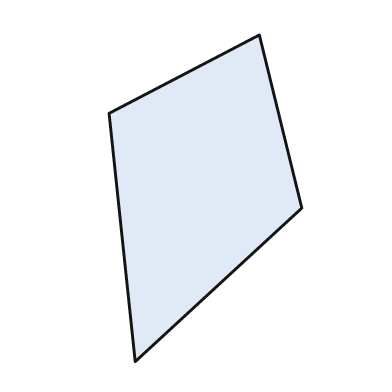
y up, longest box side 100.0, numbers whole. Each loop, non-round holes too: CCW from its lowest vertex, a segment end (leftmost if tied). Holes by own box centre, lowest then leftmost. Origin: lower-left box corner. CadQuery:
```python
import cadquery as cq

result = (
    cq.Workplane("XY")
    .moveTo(8.0, 0.0)
    .lineTo(59.0, 47.0)
    .lineTo(46.0, 100.0)
    .lineTo(0.0, 76.0)
    .close()
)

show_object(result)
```